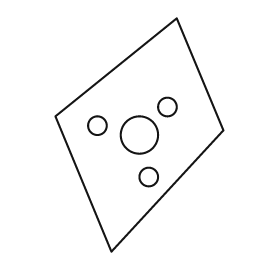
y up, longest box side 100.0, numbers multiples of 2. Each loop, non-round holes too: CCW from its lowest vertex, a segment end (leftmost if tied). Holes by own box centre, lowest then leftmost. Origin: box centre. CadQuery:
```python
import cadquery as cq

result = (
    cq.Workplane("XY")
    .moveTo(-12.0, -50.0)
    .lineTo(36.0, 2.0)
    .lineTo(16.0, 50.0)
    .lineTo(-36.0, 8.0)
    .close()
    .moveTo(4.0, -18.0)
    .circle(4.0)
    .moveTo(0.0, 0.0)
    .circle(8.0)
    .moveTo(-18.0, 4.0)
    .circle(4.0)
    .moveTo(12.0, 12.0)
    .circle(4.0)
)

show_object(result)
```